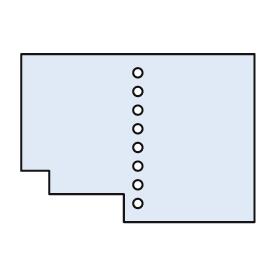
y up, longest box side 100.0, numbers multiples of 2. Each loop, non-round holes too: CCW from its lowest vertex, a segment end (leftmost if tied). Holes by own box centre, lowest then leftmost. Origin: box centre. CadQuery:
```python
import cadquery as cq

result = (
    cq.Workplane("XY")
    .moveTo(-6.0, -36.0)
    .lineTo(50.0, -36.0)
    .lineTo(50.0, 36.0)
    .lineTo(-50.0, 36.0)
    .lineTo(-50.0, -14.0)
    .lineTo(-38.0, -14.0)
    .lineTo(-38.0, -24.0)
    .lineTo(-6.0, -24.0)
    .close()
    .moveTo(0.0, -28.0)
    .circle(2.0)
    .moveTo(0.0, -20.0)
    .circle(2.0)
    .moveTo(0.0, -12.0)
    .circle(2.0)
    .moveTo(0.0, -4.0)
    .circle(2.0)
    .moveTo(0.0, 4.0)
    .circle(2.0)
    .moveTo(0.0, 12.0)
    .circle(2.0)
    .moveTo(0.0, 20.0)
    .circle(2.0)
    .moveTo(0.0, 28.0)
    .circle(2.0)
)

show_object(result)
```